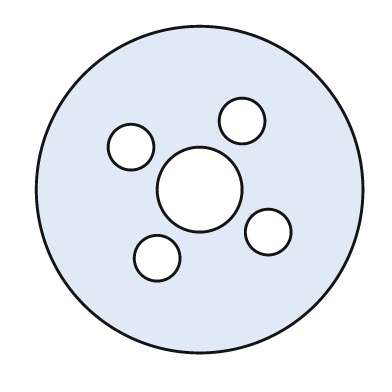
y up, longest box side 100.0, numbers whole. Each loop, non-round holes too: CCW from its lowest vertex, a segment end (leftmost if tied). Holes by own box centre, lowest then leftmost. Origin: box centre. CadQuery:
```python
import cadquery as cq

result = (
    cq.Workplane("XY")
    .moveTo(0.0, 0.0)
    .circle(50.0)
    .moveTo(-13.0, -21.0)
    .circle(7.0)
    .moveTo(21.0, -13.0)
    .circle(7.0)
    .moveTo(0.0, 0.0)
    .circle(13.0)
    .moveTo(-21.0, 13.0)
    .circle(7.0)
    .moveTo(13.0, 21.0)
    .circle(7.0)
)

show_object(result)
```